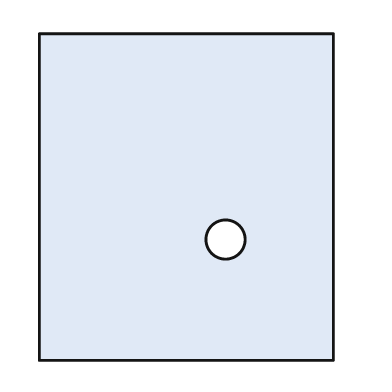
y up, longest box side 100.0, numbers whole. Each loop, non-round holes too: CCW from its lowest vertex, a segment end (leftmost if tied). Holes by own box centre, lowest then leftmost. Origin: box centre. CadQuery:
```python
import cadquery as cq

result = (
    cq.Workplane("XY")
    .moveTo(-45.0, -50.0)
    .lineTo(45.0, -50.0)
    .lineTo(45.0, 50.0)
    .lineTo(-45.0, 50.0)
    .close()
    .moveTo(12.0, -13.0)
    .circle(6.0)
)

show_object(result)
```